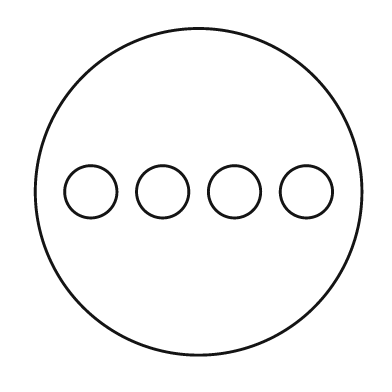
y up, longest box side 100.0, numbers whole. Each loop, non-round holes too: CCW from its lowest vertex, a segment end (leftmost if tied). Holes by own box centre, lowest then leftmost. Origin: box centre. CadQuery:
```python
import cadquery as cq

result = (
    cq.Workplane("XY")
    .moveTo(0.0, 0.0)
    .circle(50.0)
    .moveTo(-33.0, 0.0)
    .circle(8.0)
    .moveTo(-11.0, 0.0)
    .circle(8.0)
    .moveTo(11.0, 0.0)
    .circle(8.0)
    .moveTo(33.0, 0.0)
    .circle(8.0)
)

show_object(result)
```